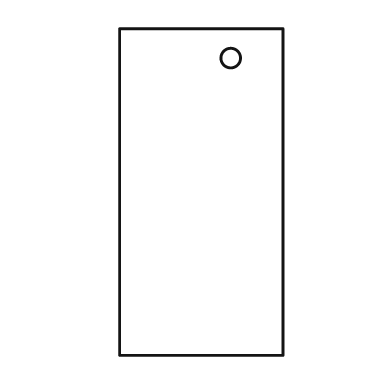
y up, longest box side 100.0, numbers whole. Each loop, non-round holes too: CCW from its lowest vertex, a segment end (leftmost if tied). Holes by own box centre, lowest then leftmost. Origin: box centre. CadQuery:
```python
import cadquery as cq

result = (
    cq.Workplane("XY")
    .moveTo(-25.0, -50.0)
    .lineTo(25.0, -50.0)
    .lineTo(25.0, 50.0)
    .lineTo(-25.0, 50.0)
    .close()
    .moveTo(9.0, 41.0)
    .circle(3.0)
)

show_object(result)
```